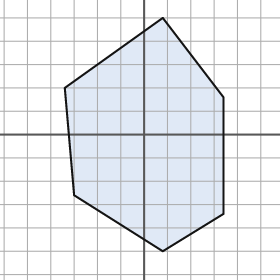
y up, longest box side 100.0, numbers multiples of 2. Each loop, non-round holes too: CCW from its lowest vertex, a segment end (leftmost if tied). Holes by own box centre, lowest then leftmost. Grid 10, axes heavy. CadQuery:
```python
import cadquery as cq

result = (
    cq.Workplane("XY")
    .moveTo(8.0, -50.0)
    .lineTo(34.0, -34.0)
    .lineTo(34.0, 16.0)
    .lineTo(8.0, 50.0)
    .lineTo(-34.0, 20.0)
    .lineTo(-30.0, -26.0)
    .close()
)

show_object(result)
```